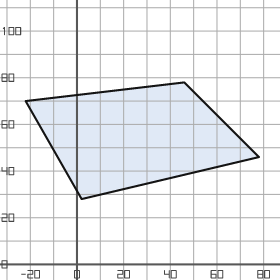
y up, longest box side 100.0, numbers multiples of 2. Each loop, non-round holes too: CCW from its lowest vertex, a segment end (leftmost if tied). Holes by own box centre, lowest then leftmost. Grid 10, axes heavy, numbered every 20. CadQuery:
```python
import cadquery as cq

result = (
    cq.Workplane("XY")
    .moveTo(2.0, 28.0)
    .lineTo(78.0, 46.0)
    .lineTo(46.0, 78.0)
    .lineTo(-22.0, 70.0)
    .close()
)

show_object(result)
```